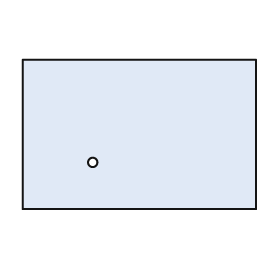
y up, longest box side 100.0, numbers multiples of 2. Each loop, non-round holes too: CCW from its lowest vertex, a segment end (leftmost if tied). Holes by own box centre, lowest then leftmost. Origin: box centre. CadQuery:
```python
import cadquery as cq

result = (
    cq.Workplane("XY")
    .moveTo(-50.0, -32.0)
    .lineTo(50.0, -32.0)
    .lineTo(50.0, 32.0)
    .lineTo(-50.0, 32.0)
    .close()
    .moveTo(-20.0, -12.0)
    .circle(2.0)
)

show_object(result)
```